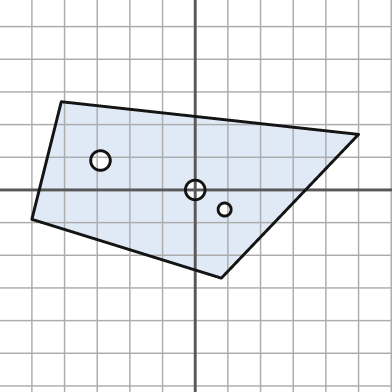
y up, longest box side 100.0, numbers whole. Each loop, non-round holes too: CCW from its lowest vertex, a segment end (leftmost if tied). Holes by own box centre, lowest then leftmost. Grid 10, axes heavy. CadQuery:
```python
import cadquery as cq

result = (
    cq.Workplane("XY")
    .moveTo(8.0, -27.0)
    .lineTo(50.0, 17.0)
    .lineTo(-41.0, 27.0)
    .lineTo(-50.0, -9.0)
    .close()
    .moveTo(9.0, -6.0)
    .circle(2.0)
    .moveTo(0.0, 0.0)
    .circle(3.0)
    .moveTo(-29.0, 9.0)
    .circle(3.0)
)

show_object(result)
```